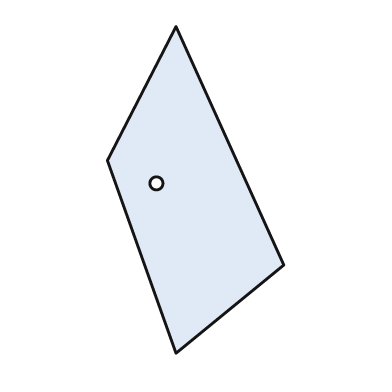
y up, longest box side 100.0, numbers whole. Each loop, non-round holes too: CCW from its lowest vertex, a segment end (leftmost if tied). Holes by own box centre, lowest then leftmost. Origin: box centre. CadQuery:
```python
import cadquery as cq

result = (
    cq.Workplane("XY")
    .moveTo(-6.0, -50.0)
    .lineTo(27.0, -23.0)
    .lineTo(-6.0, 50.0)
    .lineTo(-27.0, 9.0)
    .close()
    .moveTo(-12.0, 2.0)
    .circle(2.0)
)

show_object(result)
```